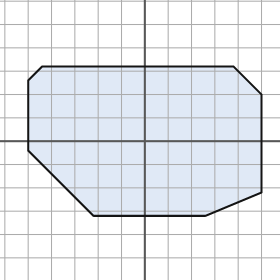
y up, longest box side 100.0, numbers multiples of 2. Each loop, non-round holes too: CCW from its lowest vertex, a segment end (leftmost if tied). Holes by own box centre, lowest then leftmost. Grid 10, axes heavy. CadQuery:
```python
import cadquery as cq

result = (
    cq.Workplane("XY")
    .moveTo(-22.0, -32.0)
    .lineTo(26.0, -32.0)
    .lineTo(50.0, -22.0)
    .lineTo(50.0, 20.0)
    .lineTo(38.0, 32.0)
    .lineTo(-44.0, 32.0)
    .lineTo(-50.0, 26.0)
    .lineTo(-50.0, -4.0)
    .close()
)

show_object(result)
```